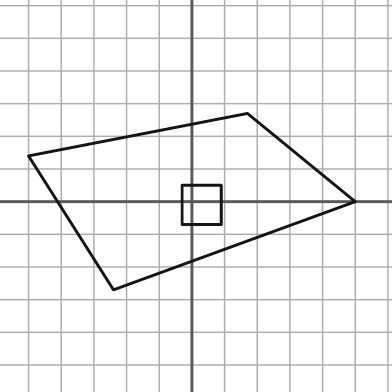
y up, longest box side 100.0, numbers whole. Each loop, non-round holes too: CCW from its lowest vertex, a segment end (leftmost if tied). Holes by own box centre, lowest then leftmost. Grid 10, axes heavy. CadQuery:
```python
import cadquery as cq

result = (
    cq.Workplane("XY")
    .moveTo(-24.0, -27.0)
    .lineTo(50.0, 0.0)
    .lineTo(17.0, 27.0)
    .lineTo(-50.0, 14.0)
    .close()
    .moveTo(-3.0, -7.0)
    .lineTo(9.0, -7.0)
    .lineTo(9.0, 5.0)
    .lineTo(-3.0, 5.0)
    .close()
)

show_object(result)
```